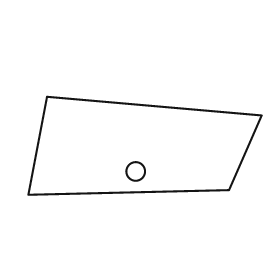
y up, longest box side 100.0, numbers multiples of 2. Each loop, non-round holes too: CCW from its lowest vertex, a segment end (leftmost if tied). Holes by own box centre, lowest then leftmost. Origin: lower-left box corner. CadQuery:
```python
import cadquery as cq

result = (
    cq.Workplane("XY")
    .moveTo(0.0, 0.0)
    .lineTo(86.0, 2.0)
    .lineTo(100.0, 34.0)
    .lineTo(8.0, 42.0)
    .close()
    .moveTo(46.0, 10.0)
    .circle(4.0)
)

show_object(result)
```